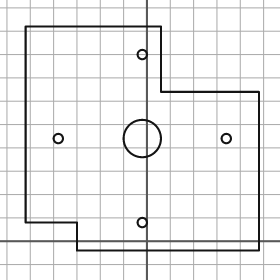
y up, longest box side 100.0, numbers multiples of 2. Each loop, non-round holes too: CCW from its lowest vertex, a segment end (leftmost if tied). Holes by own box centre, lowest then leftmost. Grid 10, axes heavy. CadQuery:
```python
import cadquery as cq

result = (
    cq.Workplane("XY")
    .moveTo(-30.0, -4.0)
    .lineTo(48.0, -4.0)
    .lineTo(48.0, 64.0)
    .lineTo(6.0, 64.0)
    .lineTo(6.0, 92.0)
    .lineTo(-52.0, 92.0)
    .lineTo(-52.0, 8.0)
    .lineTo(-30.0, 8.0)
    .close()
    .moveTo(-2.0, 8.0)
    .circle(2.0)
    .moveTo(-38.0, 44.0)
    .circle(2.0)
    .moveTo(-2.0, 44.0)
    .circle(8.0)
    .moveTo(34.0, 44.0)
    .circle(2.0)
    .moveTo(-2.0, 80.0)
    .circle(2.0)
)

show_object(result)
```